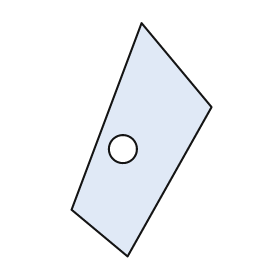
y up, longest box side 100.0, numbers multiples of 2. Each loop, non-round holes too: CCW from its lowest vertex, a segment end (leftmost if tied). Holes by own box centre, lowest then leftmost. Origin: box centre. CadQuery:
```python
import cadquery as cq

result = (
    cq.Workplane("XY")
    .moveTo(-6.0, -50.0)
    .lineTo(30.0, 14.0)
    .lineTo(0.0, 50.0)
    .lineTo(-30.0, -30.0)
    .close()
    .moveTo(-8.0, -4.0)
    .circle(6.0)
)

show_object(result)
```